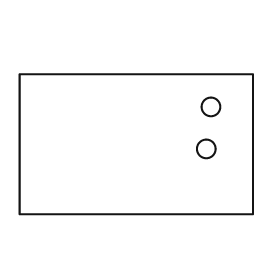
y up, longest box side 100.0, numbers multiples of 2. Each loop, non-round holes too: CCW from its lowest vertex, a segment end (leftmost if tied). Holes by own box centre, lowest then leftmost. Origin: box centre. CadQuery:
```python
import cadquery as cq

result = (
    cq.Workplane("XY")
    .moveTo(-50.0, -30.0)
    .lineTo(50.0, -30.0)
    .lineTo(50.0, 30.0)
    .lineTo(-50.0, 30.0)
    .close()
    .moveTo(30.0, -2.0)
    .circle(4.0)
    .moveTo(32.0, 16.0)
    .circle(4.0)
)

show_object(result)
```